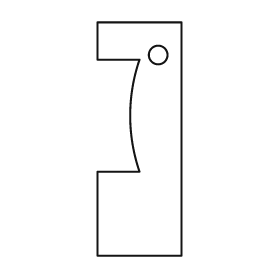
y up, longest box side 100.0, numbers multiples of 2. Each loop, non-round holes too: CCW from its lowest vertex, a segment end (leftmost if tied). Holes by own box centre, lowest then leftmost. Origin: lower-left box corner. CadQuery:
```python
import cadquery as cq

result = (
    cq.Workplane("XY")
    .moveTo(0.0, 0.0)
    .lineTo(36.0, 0.0)
    .lineTo(36.0, 100.0)
    .lineTo(0.0, 100.0)
    .lineTo(0.0, 84.0)
    .lineTo(18.0, 84.0)
    .threePointArc((14.0, 60.0), (18.0, 36.0))
    .lineTo(0.0, 36.0)
    .close()
    .moveTo(26.0, 86.0)
    .circle(4.0)
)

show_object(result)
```